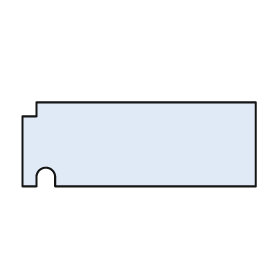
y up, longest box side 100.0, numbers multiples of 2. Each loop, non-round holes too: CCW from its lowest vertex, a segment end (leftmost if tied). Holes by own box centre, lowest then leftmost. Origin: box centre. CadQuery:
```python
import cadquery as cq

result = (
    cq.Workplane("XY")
    .moveTo(-50.0, -18.0)
    .lineTo(-44.0, -18.0)
    .lineTo(-44.0, -14.0)
    .threePointArc((-40.0, -10.0), (-36.0, -14.0))
    .lineTo(-36.0, -18.0)
    .lineTo(50.0, -18.0)
    .lineTo(50.0, 18.0)
    .lineTo(-44.0, 18.0)
    .lineTo(-44.0, 12.0)
    .lineTo(-50.0, 12.0)
    .close()
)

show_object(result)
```